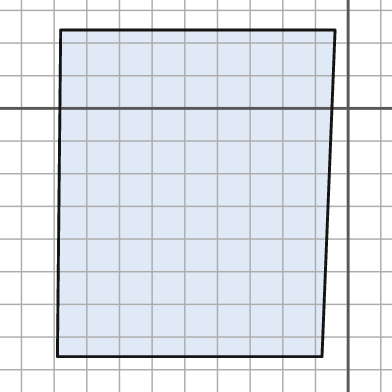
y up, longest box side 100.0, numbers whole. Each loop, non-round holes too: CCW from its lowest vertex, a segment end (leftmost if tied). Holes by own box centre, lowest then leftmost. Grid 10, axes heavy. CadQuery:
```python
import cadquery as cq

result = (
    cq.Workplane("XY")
    .moveTo(-89.0, -76.0)
    .lineTo(-8.0, -76.0)
    .lineTo(-4.0, 24.0)
    .lineTo(-88.0, 24.0)
    .close()
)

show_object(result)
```